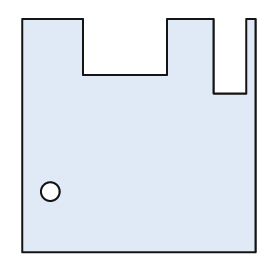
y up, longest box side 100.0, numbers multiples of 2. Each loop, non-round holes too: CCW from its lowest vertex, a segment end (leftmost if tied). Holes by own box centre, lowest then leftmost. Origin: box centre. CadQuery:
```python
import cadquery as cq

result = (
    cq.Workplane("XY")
    .moveTo(-50.0, -50.0)
    .lineTo(50.0, -50.0)
    .lineTo(50.0, 50.0)
    .lineTo(46.0, 50.0)
    .lineTo(46.0, 18.0)
    .lineTo(32.0, 18.0)
    .lineTo(32.0, 50.0)
    .lineTo(12.0, 50.0)
    .lineTo(12.0, 26.0)
    .lineTo(-24.0, 26.0)
    .lineTo(-24.0, 50.0)
    .lineTo(-50.0, 50.0)
    .close()
    .moveTo(-38.0, -24.0)
    .circle(4.0)
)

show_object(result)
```